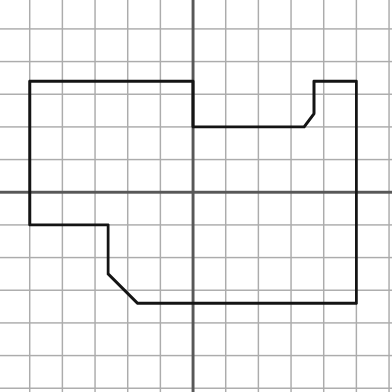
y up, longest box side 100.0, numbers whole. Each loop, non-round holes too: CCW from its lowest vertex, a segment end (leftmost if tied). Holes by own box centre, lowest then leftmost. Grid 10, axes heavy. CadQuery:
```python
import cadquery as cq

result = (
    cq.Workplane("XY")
    .moveTo(-17.0, -34.0)
    .lineTo(50.0, -34.0)
    .lineTo(50.0, 34.0)
    .lineTo(37.0, 34.0)
    .lineTo(37.0, 24.0)
    .lineTo(34.0, 20.0)
    .lineTo(0.0, 20.0)
    .lineTo(0.0, 34.0)
    .lineTo(-50.0, 34.0)
    .lineTo(-50.0, -10.0)
    .lineTo(-26.0, -10.0)
    .lineTo(-26.0, -25.0)
    .close()
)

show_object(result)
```